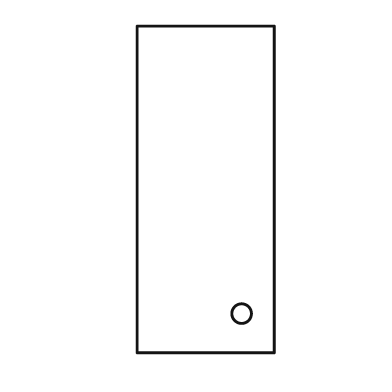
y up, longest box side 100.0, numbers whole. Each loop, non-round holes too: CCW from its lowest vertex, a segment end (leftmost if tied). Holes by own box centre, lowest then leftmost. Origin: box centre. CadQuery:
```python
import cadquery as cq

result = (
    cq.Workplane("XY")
    .moveTo(-21.0, -50.0)
    .lineTo(21.0, -50.0)
    .lineTo(21.0, 50.0)
    .lineTo(-21.0, 50.0)
    .close()
    .moveTo(11.0, -38.0)
    .circle(3.0)
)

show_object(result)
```